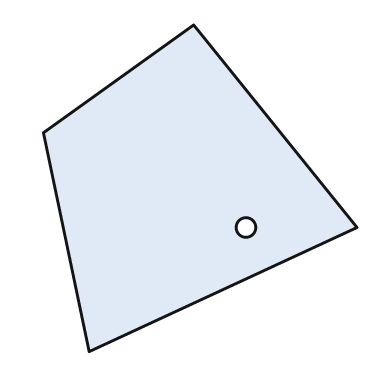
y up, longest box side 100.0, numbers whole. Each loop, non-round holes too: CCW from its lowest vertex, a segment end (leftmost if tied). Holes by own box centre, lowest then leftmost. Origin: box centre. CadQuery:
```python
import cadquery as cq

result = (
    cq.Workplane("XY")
    .moveTo(-34.0, -50.0)
    .lineTo(48.0, -12.0)
    .lineTo(-2.0, 50.0)
    .lineTo(-48.0, 17.0)
    .close()
    .moveTo(14.0, -12.0)
    .circle(3.0)
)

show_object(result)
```